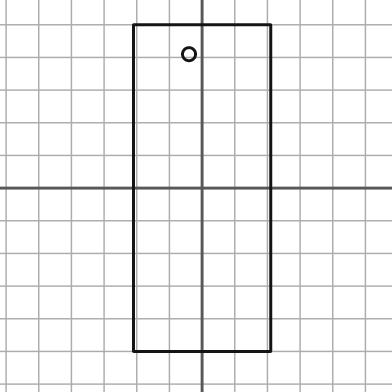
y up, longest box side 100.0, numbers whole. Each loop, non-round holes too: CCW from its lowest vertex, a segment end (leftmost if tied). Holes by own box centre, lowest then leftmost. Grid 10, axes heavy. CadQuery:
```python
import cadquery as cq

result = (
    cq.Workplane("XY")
    .moveTo(-21.0, -50.0)
    .lineTo(21.0, -50.0)
    .lineTo(21.0, 50.0)
    .lineTo(-21.0, 50.0)
    .close()
    .moveTo(-4.0, 41.0)
    .circle(2.0)
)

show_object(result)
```